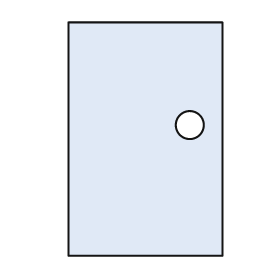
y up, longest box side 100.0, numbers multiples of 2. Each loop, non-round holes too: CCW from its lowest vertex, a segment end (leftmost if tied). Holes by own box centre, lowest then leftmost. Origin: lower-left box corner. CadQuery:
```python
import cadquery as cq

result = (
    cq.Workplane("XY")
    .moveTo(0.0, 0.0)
    .lineTo(66.0, 0.0)
    .lineTo(66.0, 100.0)
    .lineTo(0.0, 100.0)
    .close()
    .moveTo(52.0, 56.0)
    .circle(6.0)
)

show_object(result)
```